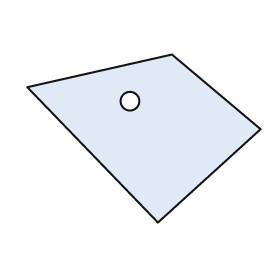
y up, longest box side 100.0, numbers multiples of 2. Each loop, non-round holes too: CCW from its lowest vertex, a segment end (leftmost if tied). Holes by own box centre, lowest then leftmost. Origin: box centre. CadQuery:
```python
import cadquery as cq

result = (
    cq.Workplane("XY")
    .moveTo(6.0, -36.0)
    .lineTo(50.0, 4.0)
    .lineTo(12.0, 36.0)
    .lineTo(-50.0, 22.0)
    .close()
    .moveTo(-6.0, 16.0)
    .circle(4.0)
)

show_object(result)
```